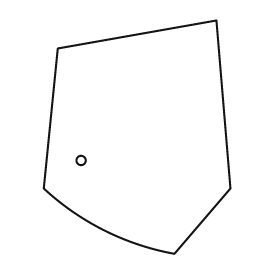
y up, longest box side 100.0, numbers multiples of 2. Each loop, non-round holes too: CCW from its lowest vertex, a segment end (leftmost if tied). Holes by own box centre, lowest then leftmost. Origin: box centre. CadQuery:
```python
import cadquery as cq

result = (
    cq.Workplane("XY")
    .moveTo(16.0, -50.0)
    .lineTo(40.0, -22.0)
    .lineTo(34.0, 50.0)
    .lineTo(-34.0, 38.0)
    .lineTo(-40.0, -22.0)
    .threePointArc((-14.0, -40.0), (16.0, -50.0))
    .close()
    .moveTo(-24.0, -10.0)
    .circle(2.0)
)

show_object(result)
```